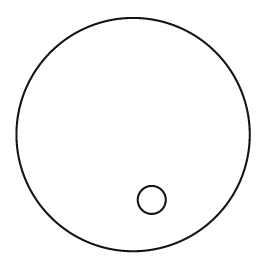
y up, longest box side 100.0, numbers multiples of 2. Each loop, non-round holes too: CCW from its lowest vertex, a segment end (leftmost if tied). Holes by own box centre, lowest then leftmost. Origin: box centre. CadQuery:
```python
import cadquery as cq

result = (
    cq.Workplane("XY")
    .moveTo(0.0, 0.0)
    .circle(50.0)
    .moveTo(8.0, -28.0)
    .circle(6.0)
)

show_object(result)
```